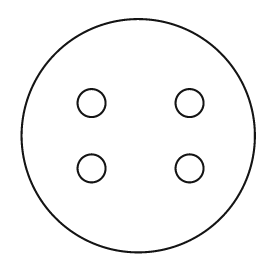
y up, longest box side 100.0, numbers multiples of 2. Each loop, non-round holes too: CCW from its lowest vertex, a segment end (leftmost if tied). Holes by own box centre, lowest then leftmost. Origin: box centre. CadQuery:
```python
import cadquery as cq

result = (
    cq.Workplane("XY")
    .moveTo(0.0, 0.0)
    .circle(50.0)
    .moveTo(-20.0, -14.0)
    .circle(6.0)
    .moveTo(22.0, -14.0)
    .circle(6.0)
    .moveTo(-20.0, 14.0)
    .circle(6.0)
    .moveTo(22.0, 14.0)
    .circle(6.0)
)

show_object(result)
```